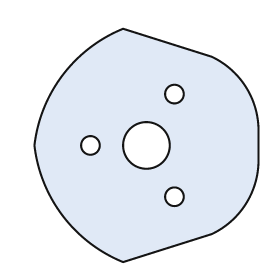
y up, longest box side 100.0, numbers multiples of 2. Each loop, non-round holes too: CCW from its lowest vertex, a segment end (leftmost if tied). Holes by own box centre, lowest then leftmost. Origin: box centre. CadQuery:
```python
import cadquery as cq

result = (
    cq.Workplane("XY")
    .moveTo(-10.0, -50.0)
    .lineTo(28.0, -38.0)
    .threePointArc((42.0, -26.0), (48.0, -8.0))
    .lineTo(48.0, 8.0)
    .threePointArc((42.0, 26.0), (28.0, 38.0))
    .lineTo(-10.0, 50.0)
    .threePointArc((-36.0, 30.0), (-48.0, 0.0))
    .threePointArc((-36.0, -30.0), (-10.0, -50.0))
    .close()
    .moveTo(12.0, -22.0)
    .circle(4.0)
    .moveTo(-24.0, 0.0)
    .circle(4.0)
    .moveTo(0.0, 0.0)
    .circle(10.0)
    .moveTo(12.0, 22.0)
    .circle(4.0)
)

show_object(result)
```